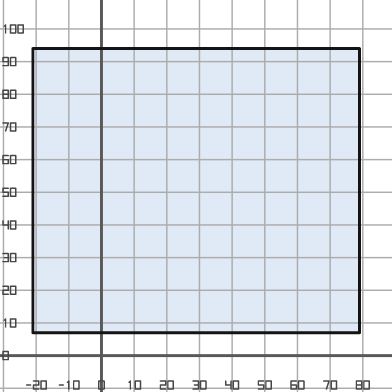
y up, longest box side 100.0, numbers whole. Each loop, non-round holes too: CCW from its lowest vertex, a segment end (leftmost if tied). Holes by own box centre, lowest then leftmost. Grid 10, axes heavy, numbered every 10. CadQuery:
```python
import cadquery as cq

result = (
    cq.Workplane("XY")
    .moveTo(-21.0, 7.0)
    .lineTo(79.0, 7.0)
    .lineTo(79.0, 94.0)
    .lineTo(-21.0, 94.0)
    .close()
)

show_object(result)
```